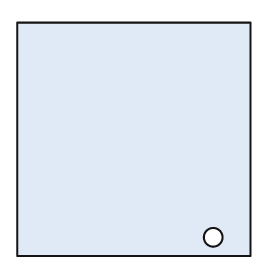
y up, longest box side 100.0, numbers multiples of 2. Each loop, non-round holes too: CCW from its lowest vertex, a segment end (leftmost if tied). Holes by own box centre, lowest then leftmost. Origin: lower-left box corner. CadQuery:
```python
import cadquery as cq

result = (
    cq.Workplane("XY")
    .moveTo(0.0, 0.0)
    .lineTo(100.0, 0.0)
    .lineTo(100.0, 100.0)
    .lineTo(0.0, 100.0)
    .close()
    .moveTo(84.0, 8.0)
    .circle(4.0)
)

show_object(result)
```